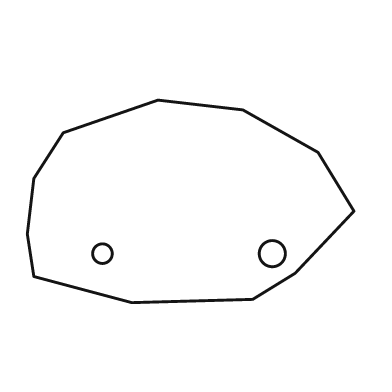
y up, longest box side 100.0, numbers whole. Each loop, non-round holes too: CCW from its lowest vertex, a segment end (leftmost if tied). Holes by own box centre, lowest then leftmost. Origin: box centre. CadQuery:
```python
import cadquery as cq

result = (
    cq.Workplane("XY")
    .moveTo(-18.0, -31.0)
    .lineTo(19.0, -30.0)
    .lineTo(32.0, -22.0)
    .lineTo(50.0, -3.0)
    .lineTo(39.0, 15.0)
    .lineTo(16.0, 28.0)
    .lineTo(-10.0, 31.0)
    .lineTo(-39.0, 21.0)
    .lineTo(-48.0, 7.0)
    .lineTo(-50.0, -10.0)
    .lineTo(-48.0, -23.0)
    .close()
    .moveTo(-27.0, -16.0)
    .circle(3.0)
    .moveTo(25.0, -16.0)
    .circle(4.0)
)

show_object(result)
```